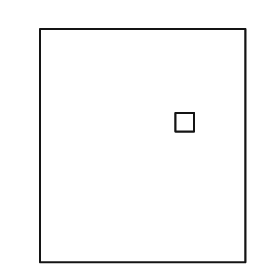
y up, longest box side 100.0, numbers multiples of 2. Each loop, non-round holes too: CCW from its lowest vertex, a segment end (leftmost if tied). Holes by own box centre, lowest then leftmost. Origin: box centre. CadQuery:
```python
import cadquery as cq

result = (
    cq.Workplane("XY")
    .moveTo(-44.0, -50.0)
    .lineTo(44.0, -50.0)
    .lineTo(44.0, 50.0)
    .lineTo(-44.0, 50.0)
    .close()
    .moveTo(14.0, 6.0)
    .lineTo(22.0, 6.0)
    .lineTo(22.0, 14.0)
    .lineTo(14.0, 14.0)
    .close()
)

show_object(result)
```